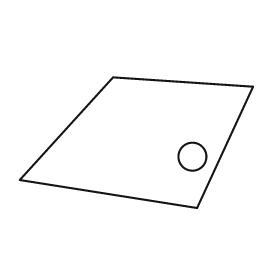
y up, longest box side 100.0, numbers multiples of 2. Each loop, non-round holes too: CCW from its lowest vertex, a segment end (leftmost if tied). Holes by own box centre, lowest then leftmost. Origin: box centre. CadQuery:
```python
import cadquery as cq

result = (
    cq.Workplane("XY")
    .moveTo(26.0, -28.0)
    .lineTo(50.0, 24.0)
    .lineTo(-10.0, 28.0)
    .lineTo(-50.0, -16.0)
    .close()
    .moveTo(24.0, -6.0)
    .circle(6.0)
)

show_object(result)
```